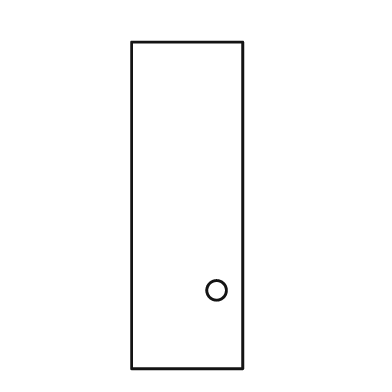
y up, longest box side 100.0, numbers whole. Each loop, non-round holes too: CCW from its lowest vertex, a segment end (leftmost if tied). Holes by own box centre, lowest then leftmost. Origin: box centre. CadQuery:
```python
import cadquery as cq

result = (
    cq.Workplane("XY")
    .moveTo(-17.0, -50.0)
    .lineTo(17.0, -50.0)
    .lineTo(17.0, 50.0)
    .lineTo(-17.0, 50.0)
    .close()
    .moveTo(9.0, -26.0)
    .circle(3.0)
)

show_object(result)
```